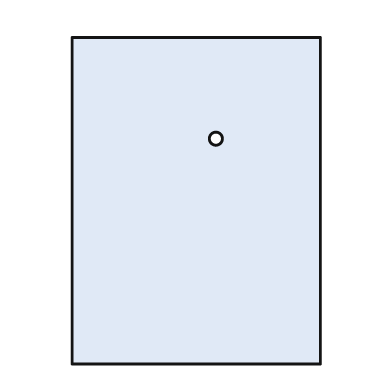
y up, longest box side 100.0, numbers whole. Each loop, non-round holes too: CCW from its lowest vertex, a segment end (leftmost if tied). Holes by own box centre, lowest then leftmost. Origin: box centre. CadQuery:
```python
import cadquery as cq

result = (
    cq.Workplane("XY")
    .moveTo(-38.0, -50.0)
    .lineTo(38.0, -50.0)
    .lineTo(38.0, 50.0)
    .lineTo(-38.0, 50.0)
    .close()
    .moveTo(6.0, 19.0)
    .circle(2.0)
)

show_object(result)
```